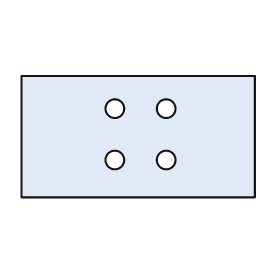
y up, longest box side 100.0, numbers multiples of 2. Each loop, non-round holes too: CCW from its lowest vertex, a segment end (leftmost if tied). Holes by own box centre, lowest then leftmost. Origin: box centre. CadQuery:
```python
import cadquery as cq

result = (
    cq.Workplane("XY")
    .moveTo(-50.0, -26.0)
    .lineTo(50.0, -26.0)
    .lineTo(50.0, 26.0)
    .lineTo(-50.0, 26.0)
    .close()
    .moveTo(-10.0, -10.0)
    .circle(4.0)
    .moveTo(12.0, -10.0)
    .circle(4.0)
    .moveTo(-10.0, 12.0)
    .circle(4.0)
    .moveTo(12.0, 12.0)
    .circle(4.0)
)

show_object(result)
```